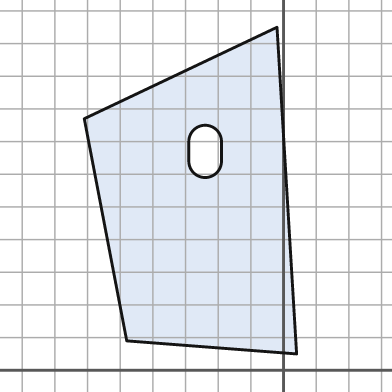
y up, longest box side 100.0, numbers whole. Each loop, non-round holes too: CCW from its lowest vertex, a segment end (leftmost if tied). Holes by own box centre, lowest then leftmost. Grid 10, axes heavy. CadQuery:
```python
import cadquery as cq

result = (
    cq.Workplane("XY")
    .moveTo(4.0, 5.0)
    .lineTo(-2.0, 105.0)
    .lineTo(-61.0, 77.0)
    .lineTo(-48.0, 9.0)
    .close()
    .moveTo(-29.0, 64.0)
    .threePointArc((-24.0, 59.0), (-19.0, 64.0))
    .lineTo(-19.0, 70.0)
    .threePointArc((-24.0, 75.0), (-29.0, 70.0))
    .close()
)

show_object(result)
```